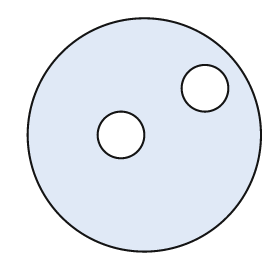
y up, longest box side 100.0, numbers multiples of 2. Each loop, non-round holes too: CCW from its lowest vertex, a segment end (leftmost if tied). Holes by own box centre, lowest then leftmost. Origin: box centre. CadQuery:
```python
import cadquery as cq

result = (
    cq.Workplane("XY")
    .moveTo(0.0, 0.0)
    .circle(50.0)
    .moveTo(-10.0, 0.0)
    .circle(10.0)
    .moveTo(26.0, 20.0)
    .circle(10.0)
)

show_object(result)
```